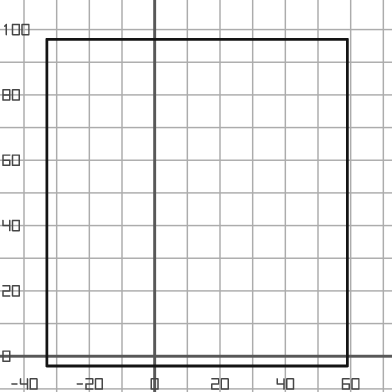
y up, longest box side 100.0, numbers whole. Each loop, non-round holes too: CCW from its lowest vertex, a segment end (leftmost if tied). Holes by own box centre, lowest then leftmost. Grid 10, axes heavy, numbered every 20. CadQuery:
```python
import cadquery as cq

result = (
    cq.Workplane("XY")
    .moveTo(-33.0, -3.0)
    .lineTo(59.0, -3.0)
    .lineTo(59.0, 97.0)
    .lineTo(-33.0, 97.0)
    .close()
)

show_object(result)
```